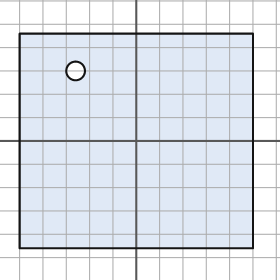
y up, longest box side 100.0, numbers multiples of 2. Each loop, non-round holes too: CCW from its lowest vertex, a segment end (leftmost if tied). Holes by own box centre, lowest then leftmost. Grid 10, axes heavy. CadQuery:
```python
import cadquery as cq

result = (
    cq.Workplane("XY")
    .moveTo(-50.0, -46.0)
    .lineTo(50.0, -46.0)
    .lineTo(50.0, 46.0)
    .lineTo(-50.0, 46.0)
    .close()
    .moveTo(-26.0, 30.0)
    .circle(4.0)
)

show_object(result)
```